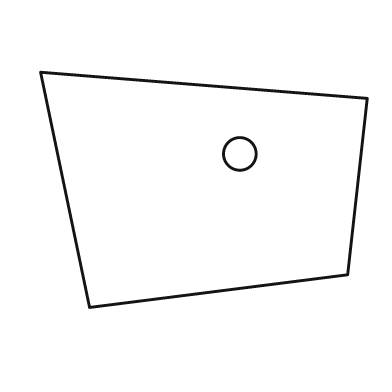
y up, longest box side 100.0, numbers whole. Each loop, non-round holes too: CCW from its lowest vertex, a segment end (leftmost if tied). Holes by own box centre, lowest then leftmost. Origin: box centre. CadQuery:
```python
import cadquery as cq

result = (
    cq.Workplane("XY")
    .moveTo(-35.0, -36.0)
    .lineTo(44.0, -26.0)
    .lineTo(50.0, 28.0)
    .lineTo(-50.0, 36.0)
    .close()
    .moveTo(11.0, 11.0)
    .circle(5.0)
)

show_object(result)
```